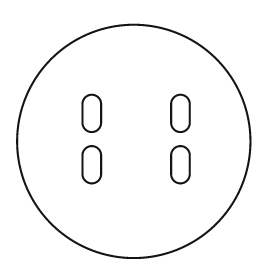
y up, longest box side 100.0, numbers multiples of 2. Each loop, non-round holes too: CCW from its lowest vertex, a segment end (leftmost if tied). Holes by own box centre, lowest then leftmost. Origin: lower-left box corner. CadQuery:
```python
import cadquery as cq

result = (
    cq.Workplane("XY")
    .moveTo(50.0, 50.0)
    .circle(50.0)
    .moveTo(28.0, 36.0)
    .threePointArc((32.0, 32.0), (36.0, 36.0))
    .lineTo(36.0, 44.0)
    .threePointArc((32.0, 48.0), (28.0, 44.0))
    .close()
    .moveTo(66.0, 36.0)
    .threePointArc((70.0, 32.0), (74.0, 36.0))
    .lineTo(74.0, 44.0)
    .threePointArc((70.0, 48.0), (66.0, 44.0))
    .close()
    .moveTo(28.0, 58.0)
    .threePointArc((32.0, 54.0), (36.0, 58.0))
    .lineTo(36.0, 66.0)
    .threePointArc((32.0, 70.0), (28.0, 66.0))
    .close()
    .moveTo(66.0, 58.0)
    .threePointArc((70.0, 54.0), (74.0, 58.0))
    .lineTo(74.0, 66.0)
    .threePointArc((70.0, 70.0), (66.0, 66.0))
    .close()
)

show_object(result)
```